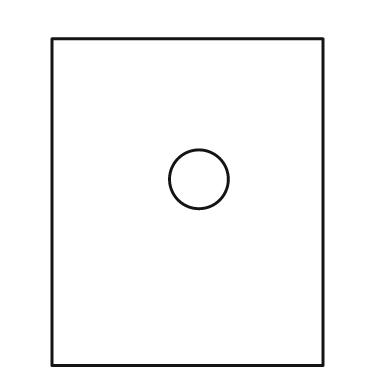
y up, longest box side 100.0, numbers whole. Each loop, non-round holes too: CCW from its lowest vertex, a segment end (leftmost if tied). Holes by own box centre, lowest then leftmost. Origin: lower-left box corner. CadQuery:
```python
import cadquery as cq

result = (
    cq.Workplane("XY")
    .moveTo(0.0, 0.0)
    .lineTo(83.0, 0.0)
    .lineTo(83.0, 100.0)
    .lineTo(0.0, 100.0)
    .close()
    .moveTo(45.0, 57.0)
    .circle(9.0)
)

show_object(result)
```